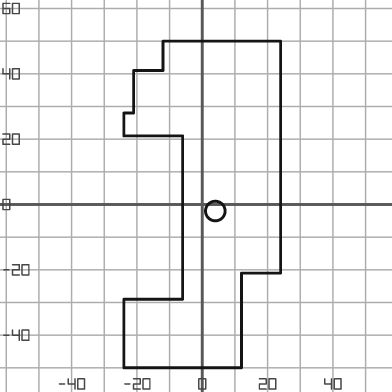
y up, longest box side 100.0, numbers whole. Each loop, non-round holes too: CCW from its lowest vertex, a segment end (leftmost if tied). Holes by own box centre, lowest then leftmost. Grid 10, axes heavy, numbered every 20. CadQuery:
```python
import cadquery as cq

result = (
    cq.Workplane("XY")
    .moveTo(-24.0, -50.0)
    .lineTo(12.0, -50.0)
    .lineTo(12.0, -21.0)
    .lineTo(24.0, -21.0)
    .lineTo(24.0, 50.0)
    .lineTo(-12.0, 50.0)
    .lineTo(-12.0, 41.0)
    .lineTo(-21.0, 41.0)
    .lineTo(-21.0, 28.0)
    .lineTo(-24.0, 28.0)
    .lineTo(-24.0, 21.0)
    .lineTo(-6.0, 21.0)
    .lineTo(-6.0, -29.0)
    .lineTo(-24.0, -29.0)
    .close()
    .moveTo(4.0, -2.0)
    .circle(3.0)
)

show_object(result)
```